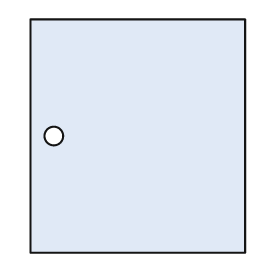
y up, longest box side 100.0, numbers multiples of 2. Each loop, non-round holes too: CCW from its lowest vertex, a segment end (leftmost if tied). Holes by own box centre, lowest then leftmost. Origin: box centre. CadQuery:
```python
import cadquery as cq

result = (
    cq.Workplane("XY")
    .moveTo(-46.0, -50.0)
    .lineTo(46.0, -50.0)
    .lineTo(46.0, 50.0)
    .lineTo(-46.0, 50.0)
    .close()
    .moveTo(-36.0, 0.0)
    .circle(4.0)
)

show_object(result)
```